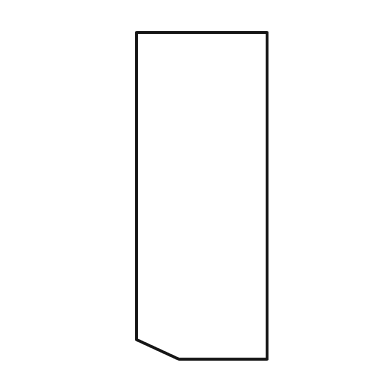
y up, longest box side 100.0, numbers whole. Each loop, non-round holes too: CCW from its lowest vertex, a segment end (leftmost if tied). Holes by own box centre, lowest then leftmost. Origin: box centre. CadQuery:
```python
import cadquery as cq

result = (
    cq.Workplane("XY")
    .moveTo(-7.0, -50.0)
    .lineTo(20.0, -50.0)
    .lineTo(20.0, 50.0)
    .lineTo(-20.0, 50.0)
    .lineTo(-20.0, -44.0)
    .close()
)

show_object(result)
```